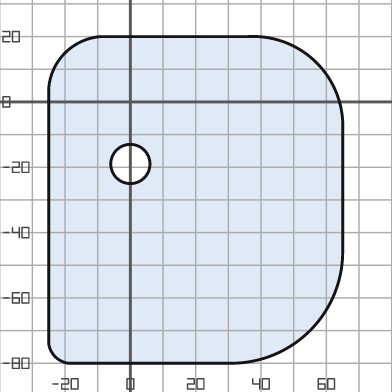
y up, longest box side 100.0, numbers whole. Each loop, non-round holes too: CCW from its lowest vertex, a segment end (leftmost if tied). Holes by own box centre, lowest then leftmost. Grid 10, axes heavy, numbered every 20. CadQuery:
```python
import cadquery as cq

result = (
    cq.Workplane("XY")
    .moveTo(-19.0, -80.0)
    .lineTo(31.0, -80.0)
    .threePointArc((55.0, -70.0), (65.0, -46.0))
    .lineTo(65.0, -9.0)
    .threePointArc((57.0, 12.0), (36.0, 20.0))
    .lineTo(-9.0, 20.0)
    .threePointArc((-20.0, 15.0), (-25.0, 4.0))
    .lineTo(-25.0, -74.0)
    .threePointArc((-23.0, -78.0), (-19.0, -80.0))
    .close()
    .moveTo(0.0, -19.0)
    .circle(6.0)
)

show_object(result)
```